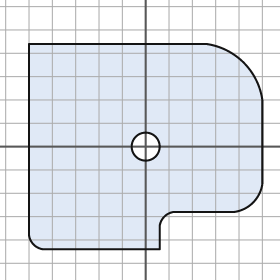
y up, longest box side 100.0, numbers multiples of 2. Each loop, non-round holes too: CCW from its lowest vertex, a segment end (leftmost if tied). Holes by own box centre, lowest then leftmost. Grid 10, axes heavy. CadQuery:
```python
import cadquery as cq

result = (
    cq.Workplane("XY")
    .moveTo(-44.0, -44.0)
    .lineTo(6.0, -44.0)
    .lineTo(6.0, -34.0)
    .threePointArc((8.0, -30.0), (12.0, -28.0))
    .lineTo(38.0, -28.0)
    .threePointArc((46.0, -24.0), (50.0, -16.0))
    .lineTo(50.0, 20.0)
    .threePointArc((42.0, 36.0), (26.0, 44.0))
    .lineTo(-50.0, 44.0)
    .lineTo(-50.0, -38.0)
    .threePointArc((-48.0, -42.0), (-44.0, -44.0))
    .close()
    .moveTo(0.0, 0.0)
    .circle(6.0)
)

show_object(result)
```